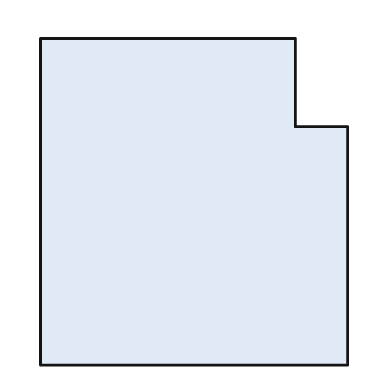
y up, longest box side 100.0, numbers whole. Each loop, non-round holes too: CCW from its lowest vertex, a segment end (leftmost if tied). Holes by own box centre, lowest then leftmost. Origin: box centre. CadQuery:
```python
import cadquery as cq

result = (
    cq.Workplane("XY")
    .moveTo(-47.0, -50.0)
    .lineTo(47.0, -50.0)
    .lineTo(47.0, 23.0)
    .lineTo(31.0, 23.0)
    .lineTo(31.0, 50.0)
    .lineTo(-47.0, 50.0)
    .close()
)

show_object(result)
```